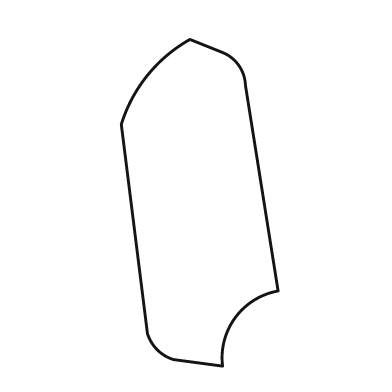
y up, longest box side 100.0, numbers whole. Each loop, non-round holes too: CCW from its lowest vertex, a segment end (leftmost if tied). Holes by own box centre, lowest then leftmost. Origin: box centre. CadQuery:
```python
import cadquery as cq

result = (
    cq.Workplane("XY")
    .moveTo(7.0, -50.0)
    .threePointArc((11.0, -35.0), (24.0, -27.0))
    .lineTo(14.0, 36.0)
    .threePointArc((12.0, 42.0), (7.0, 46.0))
    .lineTo(-3.0, 50.0)
    .threePointArc((-16.0, 39.0), (-24.0, 24.0))
    .lineTo(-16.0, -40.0)
    .threePointArc((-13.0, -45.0), (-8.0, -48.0))
    .close()
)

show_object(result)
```